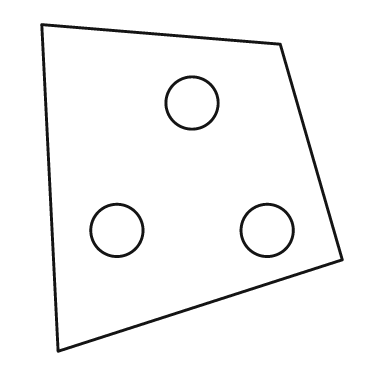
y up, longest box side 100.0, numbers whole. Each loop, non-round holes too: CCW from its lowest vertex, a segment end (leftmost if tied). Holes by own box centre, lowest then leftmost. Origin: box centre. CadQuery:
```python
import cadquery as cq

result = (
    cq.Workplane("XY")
    .moveTo(-41.0, -50.0)
    .lineTo(46.0, -22.0)
    .lineTo(27.0, 44.0)
    .lineTo(-46.0, 50.0)
    .close()
    .moveTo(-23.0, -13.0)
    .circle(8.0)
    .moveTo(23.0, -13.0)
    .circle(8.0)
    .moveTo(0.0, 26.0)
    .circle(8.0)
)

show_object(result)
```